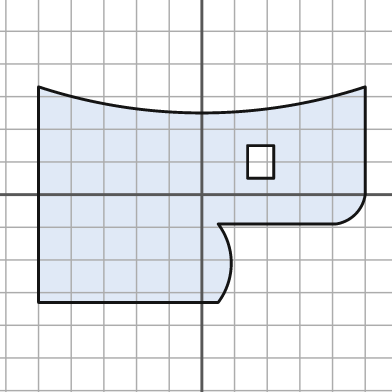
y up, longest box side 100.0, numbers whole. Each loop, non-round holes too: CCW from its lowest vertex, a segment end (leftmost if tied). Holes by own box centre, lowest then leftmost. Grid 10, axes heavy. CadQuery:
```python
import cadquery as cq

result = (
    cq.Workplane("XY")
    .moveTo(-50.0, -33.0)
    .lineTo(5.0, -33.0)
    .threePointArc((9.0, -21.0), (5.0, -9.0))
    .lineTo(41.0, -9.0)
    .threePointArc((47.0, -6.0), (50.0, 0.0))
    .lineTo(50.0, 33.0)
    .threePointArc((0.0, 25.0), (-50.0, 33.0))
    .close()
    .moveTo(14.0, 5.0)
    .lineTo(22.0, 5.0)
    .lineTo(22.0, 15.0)
    .lineTo(14.0, 15.0)
    .close()
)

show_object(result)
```